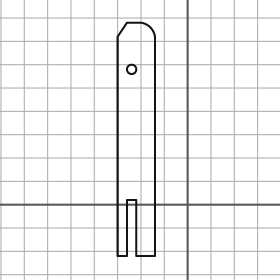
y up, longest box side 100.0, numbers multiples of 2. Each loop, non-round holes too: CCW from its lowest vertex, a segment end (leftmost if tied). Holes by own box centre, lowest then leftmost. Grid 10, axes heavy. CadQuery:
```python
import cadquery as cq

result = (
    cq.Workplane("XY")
    .moveTo(-30.0, -22.0)
    .lineTo(-26.0, -22.0)
    .lineTo(-26.0, 2.0)
    .lineTo(-22.0, 2.0)
    .lineTo(-22.0, -22.0)
    .lineTo(-14.0, -22.0)
    .lineTo(-14.0, 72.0)
    .threePointArc((-16.0, 76.0), (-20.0, 78.0))
    .lineTo(-26.0, 78.0)
    .lineTo(-30.0, 72.0)
    .close()
    .moveTo(-24.0, 58.0)
    .circle(2.0)
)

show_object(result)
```